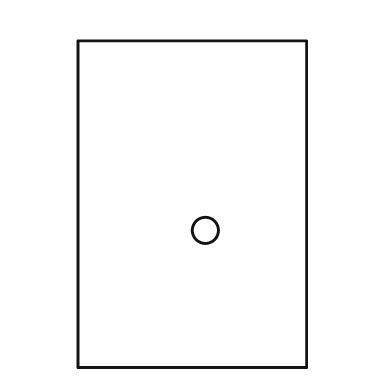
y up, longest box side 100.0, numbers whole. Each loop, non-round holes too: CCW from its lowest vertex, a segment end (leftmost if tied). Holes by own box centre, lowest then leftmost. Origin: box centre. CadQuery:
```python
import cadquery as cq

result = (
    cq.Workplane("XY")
    .moveTo(-35.0, -50.0)
    .lineTo(35.0, -50.0)
    .lineTo(35.0, 50.0)
    .lineTo(-35.0, 50.0)
    .close()
    .moveTo(4.0, -8.0)
    .circle(4.0)
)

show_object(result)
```